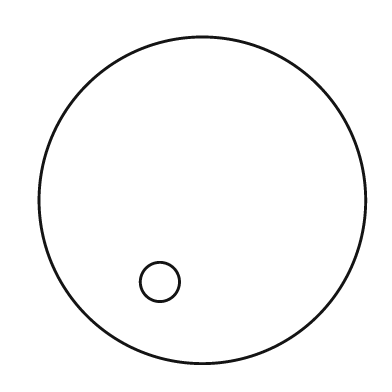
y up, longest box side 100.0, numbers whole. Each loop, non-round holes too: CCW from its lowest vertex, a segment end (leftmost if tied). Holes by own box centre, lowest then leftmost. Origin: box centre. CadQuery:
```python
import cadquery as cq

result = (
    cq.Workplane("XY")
    .moveTo(0.0, 0.0)
    .circle(50.0)
    .moveTo(-13.0, -25.0)
    .circle(6.0)
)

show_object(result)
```